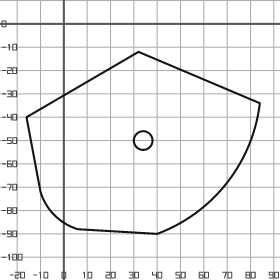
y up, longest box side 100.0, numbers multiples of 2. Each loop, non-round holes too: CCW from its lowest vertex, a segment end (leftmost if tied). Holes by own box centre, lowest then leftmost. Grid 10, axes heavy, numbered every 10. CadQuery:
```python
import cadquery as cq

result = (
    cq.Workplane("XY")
    .moveTo(40.0, -90.0)
    .threePointArc((70.0, -68.0), (84.0, -34.0))
    .lineTo(32.0, -12.0)
    .lineTo(-16.0, -40.0)
    .lineTo(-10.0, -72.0)
    .threePointArc((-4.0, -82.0), (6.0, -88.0))
    .close()
    .moveTo(34.0, -50.0)
    .circle(4.0)
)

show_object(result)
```